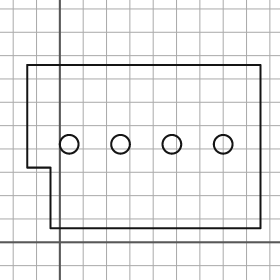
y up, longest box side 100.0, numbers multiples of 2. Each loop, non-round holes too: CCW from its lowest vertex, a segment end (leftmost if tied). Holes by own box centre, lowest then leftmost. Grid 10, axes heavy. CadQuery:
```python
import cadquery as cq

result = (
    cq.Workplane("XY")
    .moveTo(-4.0, 6.0)
    .lineTo(86.0, 6.0)
    .lineTo(86.0, 76.0)
    .lineTo(-14.0, 76.0)
    .lineTo(-14.0, 32.0)
    .lineTo(-4.0, 32.0)
    .close()
    .moveTo(4.0, 42.0)
    .circle(4.0)
    .moveTo(26.0, 42.0)
    .circle(4.0)
    .moveTo(48.0, 42.0)
    .circle(4.0)
    .moveTo(70.0, 42.0)
    .circle(4.0)
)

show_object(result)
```